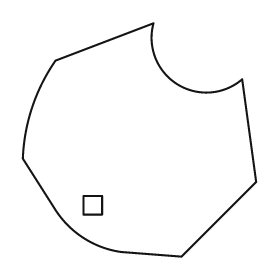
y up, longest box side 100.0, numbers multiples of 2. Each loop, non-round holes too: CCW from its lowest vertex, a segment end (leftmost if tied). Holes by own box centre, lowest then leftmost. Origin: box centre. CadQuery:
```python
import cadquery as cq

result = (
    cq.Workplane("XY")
    .moveTo(18.0, -50.0)
    .lineTo(50.0, -18.0)
    .lineTo(44.0, 26.0)
    .threePointArc((16.0, 24.0), (6.0, 50.0))
    .lineTo(-36.0, 34.0)
    .threePointArc((-46.0, 14.0), (-50.0, -8.0))
    .lineTo(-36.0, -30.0)
    .threePointArc((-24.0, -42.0), (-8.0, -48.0))
    .close()
    .moveTo(-24.0, -32.0)
    .lineTo(-16.0, -32.0)
    .lineTo(-16.0, -24.0)
    .lineTo(-24.0, -24.0)
    .close()
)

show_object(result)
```